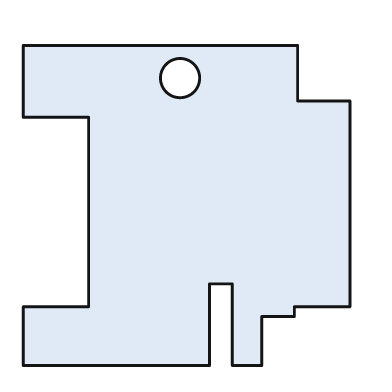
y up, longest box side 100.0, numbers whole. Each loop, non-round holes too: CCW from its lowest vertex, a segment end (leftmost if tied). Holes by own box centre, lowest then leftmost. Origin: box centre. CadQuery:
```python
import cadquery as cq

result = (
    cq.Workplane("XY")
    .moveTo(-50.0, -49.0)
    .lineTo(7.0, -49.0)
    .lineTo(7.0, -24.0)
    .lineTo(14.0, -24.0)
    .lineTo(14.0, -49.0)
    .lineTo(23.0, -49.0)
    .lineTo(23.0, -34.0)
    .lineTo(33.0, -34.0)
    .lineTo(33.0, -31.0)
    .lineTo(50.0, -31.0)
    .lineTo(50.0, 32.0)
    .lineTo(34.0, 32.0)
    .lineTo(34.0, 49.0)
    .lineTo(-50.0, 49.0)
    .lineTo(-50.0, 27.0)
    .lineTo(-30.0, 27.0)
    .lineTo(-30.0, -31.0)
    .lineTo(-50.0, -31.0)
    .close()
    .moveTo(-2.0, 39.0)
    .circle(6.0)
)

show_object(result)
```